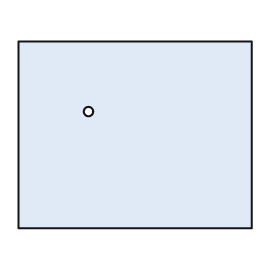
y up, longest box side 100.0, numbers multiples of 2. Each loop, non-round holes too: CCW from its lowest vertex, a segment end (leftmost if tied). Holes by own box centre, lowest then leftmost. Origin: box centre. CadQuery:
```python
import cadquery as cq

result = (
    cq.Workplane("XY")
    .moveTo(-50.0, -40.0)
    .lineTo(50.0, -40.0)
    .lineTo(50.0, 40.0)
    .lineTo(-50.0, 40.0)
    .close()
    .moveTo(-20.0, 10.0)
    .circle(2.0)
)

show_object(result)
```